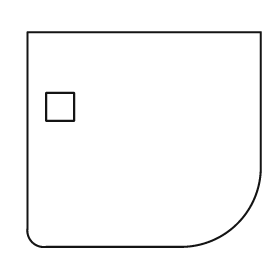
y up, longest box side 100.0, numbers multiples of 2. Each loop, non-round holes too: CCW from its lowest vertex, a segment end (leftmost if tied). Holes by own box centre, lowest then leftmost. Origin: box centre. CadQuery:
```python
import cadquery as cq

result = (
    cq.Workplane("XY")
    .moveTo(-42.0, -46.0)
    .lineTo(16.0, -46.0)
    .threePointArc((40.0, -36.0), (50.0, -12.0))
    .lineTo(50.0, 46.0)
    .lineTo(-50.0, 46.0)
    .lineTo(-50.0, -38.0)
    .threePointArc((-48.0, -44.0), (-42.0, -46.0))
    .close()
    .moveTo(-42.0, 8.0)
    .lineTo(-30.0, 8.0)
    .lineTo(-30.0, 20.0)
    .lineTo(-42.0, 20.0)
    .close()
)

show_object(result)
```